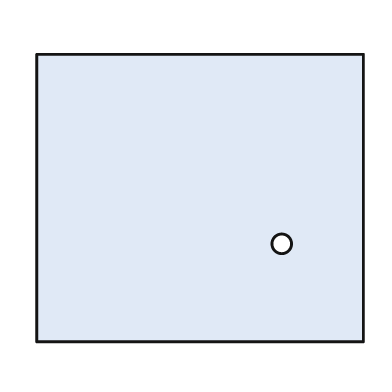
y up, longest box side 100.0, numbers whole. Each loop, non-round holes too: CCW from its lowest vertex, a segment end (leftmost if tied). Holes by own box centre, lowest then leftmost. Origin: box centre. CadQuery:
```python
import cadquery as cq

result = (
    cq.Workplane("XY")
    .moveTo(-50.0, -44.0)
    .lineTo(50.0, -44.0)
    .lineTo(50.0, 44.0)
    .lineTo(-50.0, 44.0)
    .close()
    .moveTo(25.0, -14.0)
    .circle(3.0)
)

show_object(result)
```